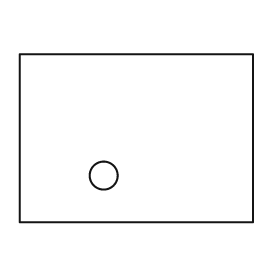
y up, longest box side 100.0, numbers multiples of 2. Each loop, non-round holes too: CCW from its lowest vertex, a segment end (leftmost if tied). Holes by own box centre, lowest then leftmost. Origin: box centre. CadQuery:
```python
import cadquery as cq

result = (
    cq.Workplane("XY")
    .moveTo(-50.0, -36.0)
    .lineTo(50.0, -36.0)
    .lineTo(50.0, 36.0)
    .lineTo(-50.0, 36.0)
    .close()
    .moveTo(-14.0, -16.0)
    .circle(6.0)
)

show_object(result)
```